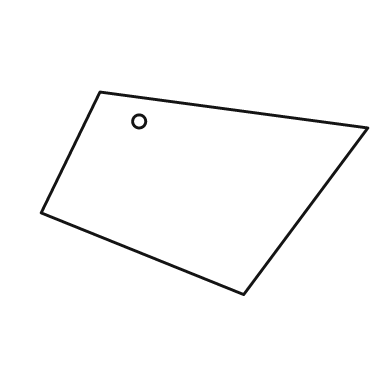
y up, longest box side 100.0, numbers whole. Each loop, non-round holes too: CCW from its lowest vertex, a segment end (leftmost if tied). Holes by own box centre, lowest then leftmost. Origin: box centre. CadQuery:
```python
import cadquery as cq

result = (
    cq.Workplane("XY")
    .moveTo(12.0, -31.0)
    .lineTo(50.0, 20.0)
    .lineTo(-32.0, 31.0)
    .lineTo(-50.0, -6.0)
    .close()
    .moveTo(-20.0, 22.0)
    .circle(2.0)
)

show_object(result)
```